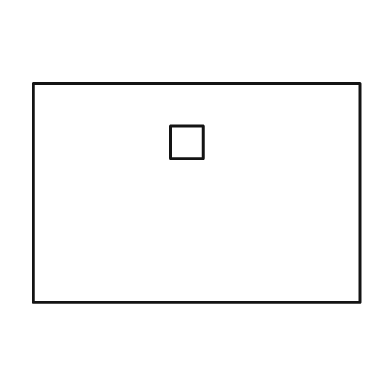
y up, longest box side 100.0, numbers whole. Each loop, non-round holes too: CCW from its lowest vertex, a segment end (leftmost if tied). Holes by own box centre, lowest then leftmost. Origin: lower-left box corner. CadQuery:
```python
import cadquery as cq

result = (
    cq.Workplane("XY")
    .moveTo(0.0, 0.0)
    .lineTo(100.0, 0.0)
    .lineTo(100.0, 67.0)
    .lineTo(0.0, 67.0)
    .close()
    .moveTo(42.0, 44.0)
    .lineTo(52.0, 44.0)
    .lineTo(52.0, 54.0)
    .lineTo(42.0, 54.0)
    .close()
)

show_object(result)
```